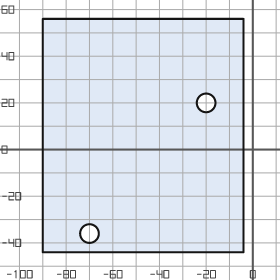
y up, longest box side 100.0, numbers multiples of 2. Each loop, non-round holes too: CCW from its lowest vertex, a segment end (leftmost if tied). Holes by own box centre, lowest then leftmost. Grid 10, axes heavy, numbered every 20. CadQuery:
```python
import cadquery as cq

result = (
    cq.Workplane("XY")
    .moveTo(-90.0, -44.0)
    .lineTo(-4.0, -44.0)
    .lineTo(-4.0, 56.0)
    .lineTo(-90.0, 56.0)
    .close()
    .moveTo(-70.0, -36.0)
    .circle(4.0)
    .moveTo(-20.0, 20.0)
    .circle(4.0)
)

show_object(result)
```